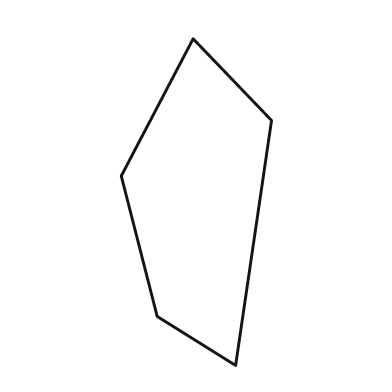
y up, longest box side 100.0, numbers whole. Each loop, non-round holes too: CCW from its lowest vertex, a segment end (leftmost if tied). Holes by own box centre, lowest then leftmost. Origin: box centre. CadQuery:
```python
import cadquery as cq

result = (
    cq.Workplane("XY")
    .moveTo(12.0, -50.0)
    .lineTo(23.0, 25.0)
    .lineTo(-1.0, 50.0)
    .lineTo(-23.0, 8.0)
    .lineTo(-12.0, -35.0)
    .close()
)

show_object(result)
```